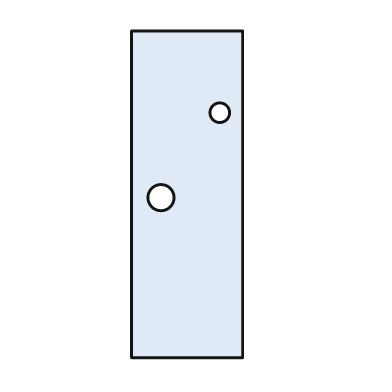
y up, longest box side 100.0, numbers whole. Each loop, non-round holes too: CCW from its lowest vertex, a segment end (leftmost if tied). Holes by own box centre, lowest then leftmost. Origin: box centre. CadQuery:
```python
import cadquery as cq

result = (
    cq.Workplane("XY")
    .moveTo(-17.0, -50.0)
    .lineTo(17.0, -50.0)
    .lineTo(17.0, 50.0)
    .lineTo(-17.0, 50.0)
    .close()
    .moveTo(-8.0, -1.0)
    .circle(4.0)
    .moveTo(10.0, 25.0)
    .circle(3.0)
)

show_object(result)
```